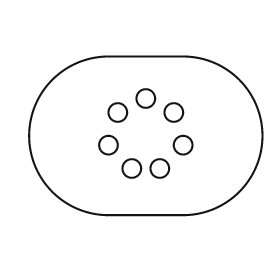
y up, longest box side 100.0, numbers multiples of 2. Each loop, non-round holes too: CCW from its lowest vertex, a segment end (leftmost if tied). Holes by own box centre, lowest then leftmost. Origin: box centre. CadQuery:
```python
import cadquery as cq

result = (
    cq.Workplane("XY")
    .moveTo(-16.0, -34.0)
    .lineTo(16.0, -34.0)
    .threePointArc((50.0, 0.0), (16.0, 34.0))
    .lineTo(-16.0, 34.0)
    .threePointArc((-50.0, 0.0), (-16.0, -34.0))
    .close()
    .moveTo(-6.0, -14.0)
    .circle(4.0)
    .moveTo(6.0, -14.0)
    .circle(4.0)
    .moveTo(-16.0, -4.0)
    .circle(4.0)
    .moveTo(16.0, -4.0)
    .circle(4.0)
    .moveTo(-12.0, 10.0)
    .circle(4.0)
    .moveTo(12.0, 10.0)
    .circle(4.0)
    .moveTo(0.0, 16.0)
    .circle(4.0)
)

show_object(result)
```